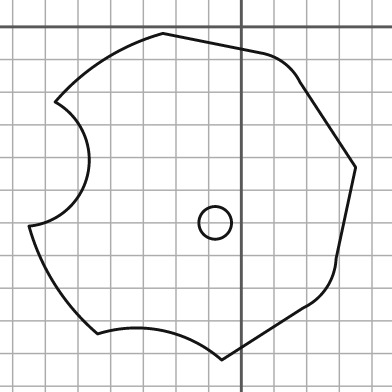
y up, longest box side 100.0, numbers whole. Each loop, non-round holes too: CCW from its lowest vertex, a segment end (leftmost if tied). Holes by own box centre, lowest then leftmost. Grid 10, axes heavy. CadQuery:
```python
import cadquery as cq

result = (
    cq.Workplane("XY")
    .moveTo(-6.0, -102.0)
    .lineTo(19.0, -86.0)
    .threePointArc((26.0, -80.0), (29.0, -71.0))
    .lineTo(35.0, -43.0)
    .lineTo(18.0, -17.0)
    .threePointArc((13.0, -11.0), (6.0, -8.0))
    .lineTo(-24.0, -2.0)
    .threePointArc((-42.0, -10.0), (-57.0, -23.0))
    .threePointArc((-47.0, -45.0), (-65.0, -61.0))
    .threePointArc((-57.0, -79.0), (-44.0, -94.0))
    .threePointArc((-24.0, -93.0), (-6.0, -102.0))
    .close()
    .moveTo(-8.0, -60.0)
    .circle(5.0)
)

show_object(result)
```